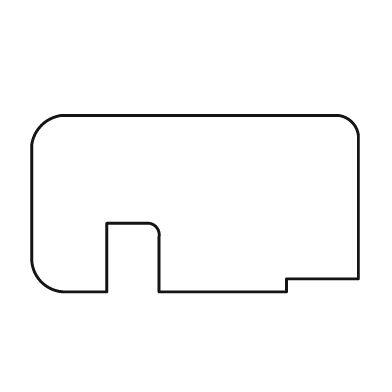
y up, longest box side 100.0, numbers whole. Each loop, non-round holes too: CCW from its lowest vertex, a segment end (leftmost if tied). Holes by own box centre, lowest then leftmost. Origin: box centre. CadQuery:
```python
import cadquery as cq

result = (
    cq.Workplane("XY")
    .moveTo(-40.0, -27.0)
    .lineTo(-27.0, -27.0)
    .lineTo(-27.0, -6.0)
    .lineTo(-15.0, -6.0)
    .threePointArc((-12.0, -7.0), (-11.0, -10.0))
    .lineTo(-11.0, -27.0)
    .lineTo(28.0, -27.0)
    .lineTo(28.0, -23.0)
    .lineTo(50.0, -23.0)
    .lineTo(50.0, 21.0)
    .threePointArc((48.0, 25.0), (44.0, 27.0))
    .lineTo(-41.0, 27.0)
    .threePointArc((-47.0, 24.0), (-50.0, 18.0))
    .lineTo(-50.0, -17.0)
    .threePointArc((-47.0, -24.0), (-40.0, -27.0))
    .close()
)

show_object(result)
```